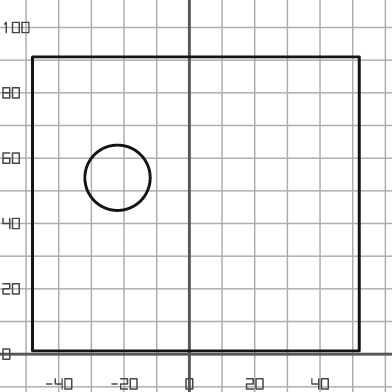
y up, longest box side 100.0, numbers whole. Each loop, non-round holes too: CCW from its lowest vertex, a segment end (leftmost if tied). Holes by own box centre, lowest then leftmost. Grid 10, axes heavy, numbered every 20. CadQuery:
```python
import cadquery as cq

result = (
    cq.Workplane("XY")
    .moveTo(-48.0, 1.0)
    .lineTo(52.0, 1.0)
    .lineTo(52.0, 91.0)
    .lineTo(-48.0, 91.0)
    .close()
    .moveTo(-22.0, 54.0)
    .circle(10.0)
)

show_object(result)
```